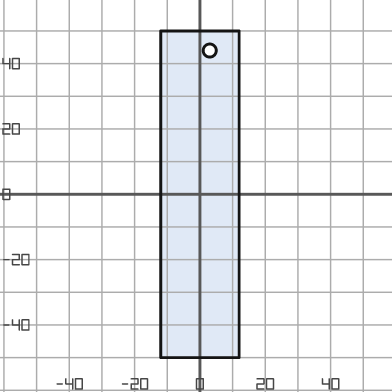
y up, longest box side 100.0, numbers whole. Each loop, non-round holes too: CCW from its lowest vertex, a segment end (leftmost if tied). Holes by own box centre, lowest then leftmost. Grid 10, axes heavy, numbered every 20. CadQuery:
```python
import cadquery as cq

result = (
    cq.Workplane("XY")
    .moveTo(-12.0, -50.0)
    .lineTo(12.0, -50.0)
    .lineTo(12.0, 50.0)
    .lineTo(-12.0, 50.0)
    .close()
    .moveTo(3.0, 44.0)
    .circle(2.0)
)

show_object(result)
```